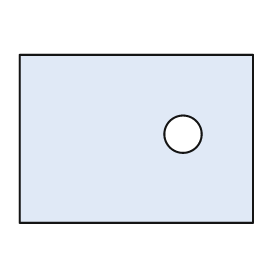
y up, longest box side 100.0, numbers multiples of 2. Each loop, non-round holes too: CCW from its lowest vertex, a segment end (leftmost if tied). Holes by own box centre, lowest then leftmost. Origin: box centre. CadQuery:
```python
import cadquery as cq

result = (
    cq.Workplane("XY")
    .moveTo(-50.0, -36.0)
    .lineTo(50.0, -36.0)
    .lineTo(50.0, 36.0)
    .lineTo(-50.0, 36.0)
    .close()
    .moveTo(20.0, 2.0)
    .circle(8.0)
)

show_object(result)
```